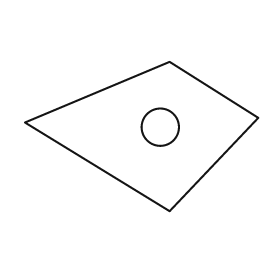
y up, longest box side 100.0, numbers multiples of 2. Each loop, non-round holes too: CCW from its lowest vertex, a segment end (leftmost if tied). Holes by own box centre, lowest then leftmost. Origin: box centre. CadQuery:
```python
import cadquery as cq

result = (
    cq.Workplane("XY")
    .moveTo(12.0, -32.0)
    .lineTo(50.0, 8.0)
    .lineTo(12.0, 32.0)
    .lineTo(-50.0, 6.0)
    .close()
    .moveTo(8.0, 4.0)
    .circle(8.0)
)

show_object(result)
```